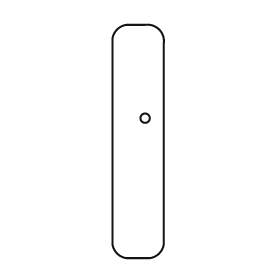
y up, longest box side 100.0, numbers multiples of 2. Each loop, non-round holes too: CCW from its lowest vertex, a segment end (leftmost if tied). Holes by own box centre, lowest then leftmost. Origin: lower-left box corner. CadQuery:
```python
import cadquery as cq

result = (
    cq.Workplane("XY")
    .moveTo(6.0, 0.0)
    .lineTo(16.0, 0.0)
    .threePointArc((20.0, 2.0), (22.0, 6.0))
    .lineTo(22.0, 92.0)
    .threePointArc((20.0, 98.0), (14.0, 100.0))
    .lineTo(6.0, 100.0)
    .threePointArc((2.0, 98.0), (0.0, 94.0))
    .lineTo(0.0, 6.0)
    .threePointArc((2.0, 2.0), (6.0, 0.0))
    .close()
    .moveTo(14.0, 60.0)
    .circle(2.0)
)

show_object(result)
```